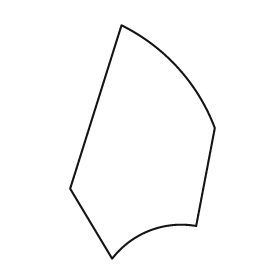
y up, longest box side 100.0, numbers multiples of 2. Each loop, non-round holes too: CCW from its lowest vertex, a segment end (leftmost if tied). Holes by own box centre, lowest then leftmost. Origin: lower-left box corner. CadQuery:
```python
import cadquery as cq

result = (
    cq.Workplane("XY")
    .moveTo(18.0, 0.0)
    .threePointArc((34.0, 12.0), (54.0, 14.0))
    .lineTo(62.0, 56.0)
    .threePointArc((46.0, 82.0), (22.0, 100.0))
    .lineTo(0.0, 30.0)
    .close()
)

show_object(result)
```